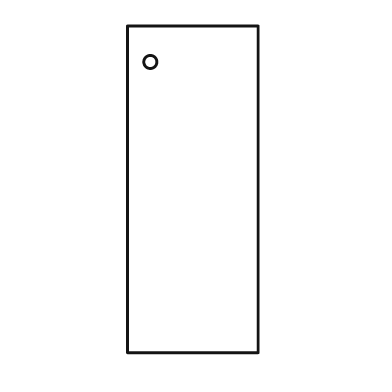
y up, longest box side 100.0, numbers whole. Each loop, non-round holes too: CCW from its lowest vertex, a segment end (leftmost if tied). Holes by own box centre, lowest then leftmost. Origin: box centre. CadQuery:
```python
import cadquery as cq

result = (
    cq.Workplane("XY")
    .moveTo(-20.0, -50.0)
    .lineTo(20.0, -50.0)
    .lineTo(20.0, 50.0)
    .lineTo(-20.0, 50.0)
    .close()
    .moveTo(-13.0, 39.0)
    .circle(2.0)
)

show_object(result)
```